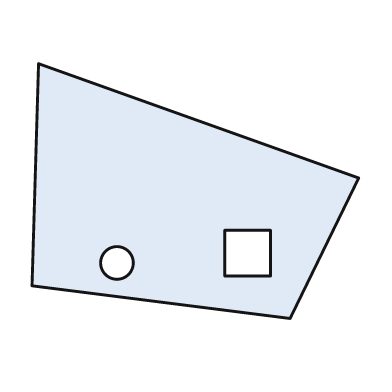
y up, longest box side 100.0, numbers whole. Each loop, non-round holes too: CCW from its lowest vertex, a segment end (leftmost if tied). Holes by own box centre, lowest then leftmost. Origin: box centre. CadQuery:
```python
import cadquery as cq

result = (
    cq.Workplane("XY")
    .moveTo(29.0, -39.0)
    .lineTo(50.0, 4.0)
    .lineTo(-48.0, 39.0)
    .lineTo(-50.0, -29.0)
    .close()
    .moveTo(-24.0, -22.0)
    .circle(5.0)
    .moveTo(9.0, -26.0)
    .lineTo(23.0, -26.0)
    .lineTo(23.0, -12.0)
    .lineTo(9.0, -12.0)
    .close()
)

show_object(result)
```